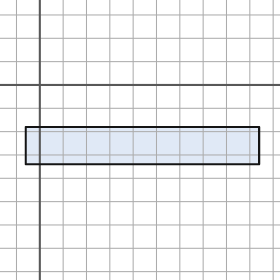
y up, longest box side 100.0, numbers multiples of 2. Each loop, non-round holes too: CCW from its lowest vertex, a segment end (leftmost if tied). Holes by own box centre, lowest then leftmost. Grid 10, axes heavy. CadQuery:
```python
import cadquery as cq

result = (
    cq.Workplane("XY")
    .moveTo(-6.0, -34.0)
    .lineTo(94.0, -34.0)
    .lineTo(94.0, -18.0)
    .lineTo(-6.0, -18.0)
    .close()
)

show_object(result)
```